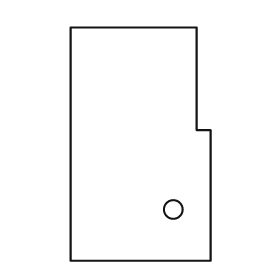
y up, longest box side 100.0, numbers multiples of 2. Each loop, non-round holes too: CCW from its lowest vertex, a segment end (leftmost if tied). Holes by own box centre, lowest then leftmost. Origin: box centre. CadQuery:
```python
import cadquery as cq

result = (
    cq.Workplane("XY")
    .moveTo(-30.0, -50.0)
    .lineTo(30.0, -50.0)
    .lineTo(30.0, 6.0)
    .lineTo(24.0, 6.0)
    .lineTo(24.0, 50.0)
    .lineTo(-30.0, 50.0)
    .close()
    .moveTo(14.0, -28.0)
    .circle(4.0)
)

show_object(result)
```